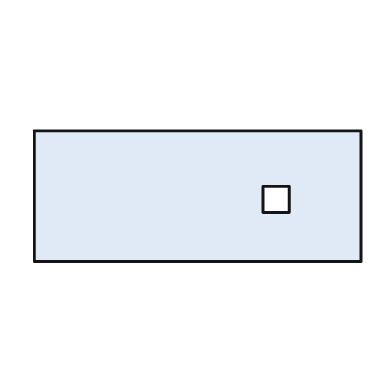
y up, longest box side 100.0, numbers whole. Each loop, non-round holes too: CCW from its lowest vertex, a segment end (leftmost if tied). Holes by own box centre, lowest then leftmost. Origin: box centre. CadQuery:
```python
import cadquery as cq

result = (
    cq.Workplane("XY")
    .moveTo(-50.0, -20.0)
    .lineTo(50.0, -20.0)
    .lineTo(50.0, 20.0)
    .lineTo(-50.0, 20.0)
    .close()
    .moveTo(20.0, -5.0)
    .lineTo(28.0, -5.0)
    .lineTo(28.0, 3.0)
    .lineTo(20.0, 3.0)
    .close()
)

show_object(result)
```